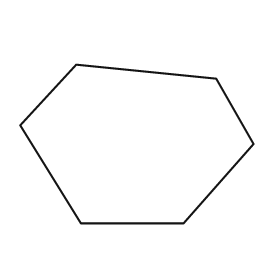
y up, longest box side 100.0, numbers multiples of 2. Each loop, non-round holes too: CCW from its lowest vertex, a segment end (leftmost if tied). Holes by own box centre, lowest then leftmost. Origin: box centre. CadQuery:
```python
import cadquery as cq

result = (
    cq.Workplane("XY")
    .moveTo(-24.0, -34.0)
    .lineTo(20.0, -34.0)
    .lineTo(50.0, 0.0)
    .lineTo(34.0, 28.0)
    .lineTo(-26.0, 34.0)
    .lineTo(-50.0, 8.0)
    .close()
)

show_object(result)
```